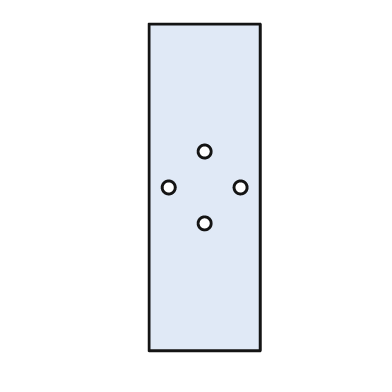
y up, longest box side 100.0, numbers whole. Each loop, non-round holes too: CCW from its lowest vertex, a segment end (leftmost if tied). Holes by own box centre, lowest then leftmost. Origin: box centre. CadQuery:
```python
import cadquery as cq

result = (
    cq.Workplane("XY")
    .moveTo(-17.0, -50.0)
    .lineTo(17.0, -50.0)
    .lineTo(17.0, 50.0)
    .lineTo(-17.0, 50.0)
    .close()
    .moveTo(0.0, -11.0)
    .circle(2.0)
    .moveTo(-11.0, 0.0)
    .circle(2.0)
    .moveTo(11.0, 0.0)
    .circle(2.0)
    .moveTo(0.0, 11.0)
    .circle(2.0)
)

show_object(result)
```